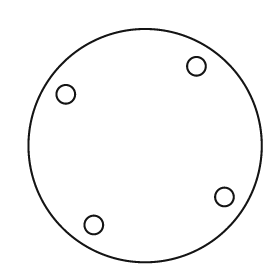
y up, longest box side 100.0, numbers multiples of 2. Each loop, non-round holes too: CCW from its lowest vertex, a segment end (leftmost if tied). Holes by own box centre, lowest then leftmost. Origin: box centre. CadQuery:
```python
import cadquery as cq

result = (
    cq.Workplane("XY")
    .moveTo(0.0, 0.0)
    .circle(50.0)
    .moveTo(-22.0, -34.0)
    .circle(4.0)
    .moveTo(34.0, -22.0)
    .circle(4.0)
    .moveTo(-34.0, 22.0)
    .circle(4.0)
    .moveTo(22.0, 34.0)
    .circle(4.0)
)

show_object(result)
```